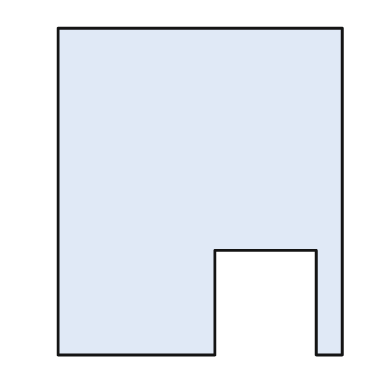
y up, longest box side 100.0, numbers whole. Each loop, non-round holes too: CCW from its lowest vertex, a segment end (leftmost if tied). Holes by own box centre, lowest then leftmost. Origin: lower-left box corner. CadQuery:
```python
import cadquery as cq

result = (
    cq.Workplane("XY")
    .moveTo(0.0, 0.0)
    .lineTo(48.0, 0.0)
    .lineTo(48.0, 32.0)
    .lineTo(79.0, 32.0)
    .lineTo(79.0, 0.0)
    .lineTo(87.0, 0.0)
    .lineTo(87.0, 100.0)
    .lineTo(0.0, 100.0)
    .close()
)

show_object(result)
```